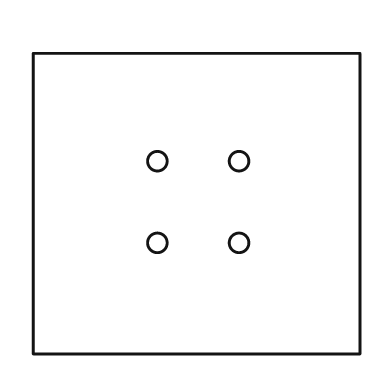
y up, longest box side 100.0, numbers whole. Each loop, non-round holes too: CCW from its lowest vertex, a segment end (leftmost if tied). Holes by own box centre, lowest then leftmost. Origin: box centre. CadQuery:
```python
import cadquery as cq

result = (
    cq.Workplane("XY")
    .moveTo(-50.0, -46.0)
    .lineTo(50.0, -46.0)
    .lineTo(50.0, 46.0)
    .lineTo(-50.0, 46.0)
    .close()
    .moveTo(-12.0, -12.0)
    .circle(3.0)
    .moveTo(13.0, -12.0)
    .circle(3.0)
    .moveTo(-12.0, 13.0)
    .circle(3.0)
    .moveTo(13.0, 13.0)
    .circle(3.0)
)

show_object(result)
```